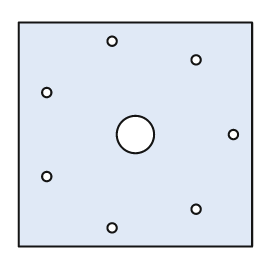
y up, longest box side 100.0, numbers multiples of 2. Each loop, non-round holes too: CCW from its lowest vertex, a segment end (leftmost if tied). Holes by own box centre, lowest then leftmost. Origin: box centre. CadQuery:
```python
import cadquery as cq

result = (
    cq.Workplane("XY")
    .moveTo(-50.0, -48.0)
    .lineTo(50.0, -48.0)
    .lineTo(50.0, 48.0)
    .lineTo(-50.0, 48.0)
    .close()
    .moveTo(-10.0, -40.0)
    .circle(2.0)
    .moveTo(26.0, -32.0)
    .circle(2.0)
    .moveTo(-38.0, -18.0)
    .circle(2.0)
    .moveTo(0.0, 0.0)
    .circle(8.0)
    .moveTo(42.0, 0.0)
    .circle(2.0)
    .moveTo(-38.0, 18.0)
    .circle(2.0)
    .moveTo(26.0, 32.0)
    .circle(2.0)
    .moveTo(-10.0, 40.0)
    .circle(2.0)
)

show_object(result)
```